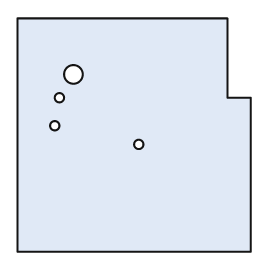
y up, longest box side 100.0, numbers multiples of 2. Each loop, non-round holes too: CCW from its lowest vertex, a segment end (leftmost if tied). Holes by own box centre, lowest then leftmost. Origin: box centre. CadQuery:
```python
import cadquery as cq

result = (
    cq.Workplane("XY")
    .moveTo(-50.0, -50.0)
    .lineTo(50.0, -50.0)
    .lineTo(50.0, 16.0)
    .lineTo(40.0, 16.0)
    .lineTo(40.0, 50.0)
    .lineTo(-50.0, 50.0)
    .close()
    .moveTo(2.0, -4.0)
    .circle(2.0)
    .moveTo(-34.0, 4.0)
    .circle(2.0)
    .moveTo(-32.0, 16.0)
    .circle(2.0)
    .moveTo(-26.0, 26.0)
    .circle(4.0)
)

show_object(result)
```